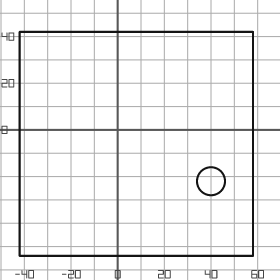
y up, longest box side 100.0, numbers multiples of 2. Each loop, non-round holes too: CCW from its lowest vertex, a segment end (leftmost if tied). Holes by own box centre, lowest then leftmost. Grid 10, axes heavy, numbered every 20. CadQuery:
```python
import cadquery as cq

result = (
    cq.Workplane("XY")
    .moveTo(-42.0, -54.0)
    .lineTo(58.0, -54.0)
    .lineTo(58.0, 42.0)
    .lineTo(-42.0, 42.0)
    .close()
    .moveTo(40.0, -22.0)
    .circle(6.0)
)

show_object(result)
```